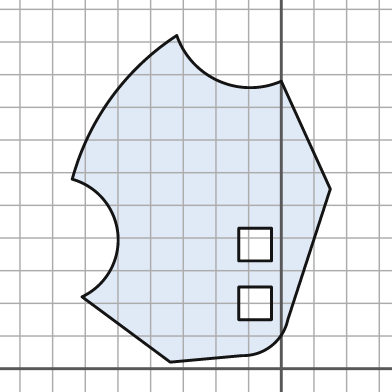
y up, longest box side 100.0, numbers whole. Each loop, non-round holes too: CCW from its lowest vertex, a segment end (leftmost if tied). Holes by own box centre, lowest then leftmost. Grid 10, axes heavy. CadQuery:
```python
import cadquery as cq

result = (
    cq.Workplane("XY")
    .moveTo(-34.0, 2.0)
    .lineTo(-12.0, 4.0)
    .threePointArc((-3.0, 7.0), (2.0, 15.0))
    .lineTo(15.0, 55.0)
    .lineTo(0.0, 88.0)
    .threePointArc((-19.0, 88.0), (-32.0, 102.0))
    .threePointArc((-52.0, 83.0), (-64.0, 58.0))
    .threePointArc((-50.0, 41.0), (-61.0, 22.0))
    .close()
    .moveTo(-13.0, 15.0)
    .lineTo(-3.0, 15.0)
    .lineTo(-3.0, 25.0)
    .lineTo(-13.0, 25.0)
    .close()
    .moveTo(-13.0, 33.0)
    .lineTo(-3.0, 33.0)
    .lineTo(-3.0, 43.0)
    .lineTo(-13.0, 43.0)
    .close()
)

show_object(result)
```